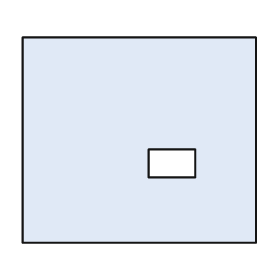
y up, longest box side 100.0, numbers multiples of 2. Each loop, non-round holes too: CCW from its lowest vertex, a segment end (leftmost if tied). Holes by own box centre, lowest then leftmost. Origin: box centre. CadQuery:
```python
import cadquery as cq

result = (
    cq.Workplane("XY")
    .moveTo(-50.0, -44.0)
    .lineTo(50.0, -44.0)
    .lineTo(50.0, 44.0)
    .lineTo(-50.0, 44.0)
    .close()
    .moveTo(4.0, -16.0)
    .lineTo(24.0, -16.0)
    .lineTo(24.0, -4.0)
    .lineTo(4.0, -4.0)
    .close()
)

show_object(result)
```